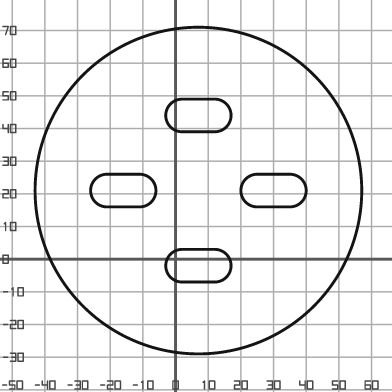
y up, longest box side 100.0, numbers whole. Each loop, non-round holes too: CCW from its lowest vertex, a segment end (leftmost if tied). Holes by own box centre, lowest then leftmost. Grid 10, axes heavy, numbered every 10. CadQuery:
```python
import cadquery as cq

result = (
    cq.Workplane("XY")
    .moveTo(7.0, 21.0)
    .circle(50.0)
    .moveTo(2.0, -7.0)
    .lineTo(12.0, -7.0)
    .threePointArc((17.0, -2.0), (12.0, 3.0))
    .lineTo(2.0, 3.0)
    .threePointArc((-3.0, -2.0), (2.0, -7.0))
    .close()
    .moveTo(-21.0, 16.0)
    .lineTo(-11.0, 16.0)
    .threePointArc((-6.0, 21.0), (-11.0, 26.0))
    .lineTo(-21.0, 26.0)
    .threePointArc((-26.0, 21.0), (-21.0, 16.0))
    .close()
    .moveTo(25.0, 16.0)
    .lineTo(35.0, 16.0)
    .threePointArc((40.0, 21.0), (35.0, 26.0))
    .lineTo(25.0, 26.0)
    .threePointArc((20.0, 21.0), (25.0, 16.0))
    .close()
    .moveTo(2.0, 39.0)
    .lineTo(12.0, 39.0)
    .threePointArc((17.0, 44.0), (12.0, 49.0))
    .lineTo(2.0, 49.0)
    .threePointArc((-3.0, 44.0), (2.0, 39.0))
    .close()
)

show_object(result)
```